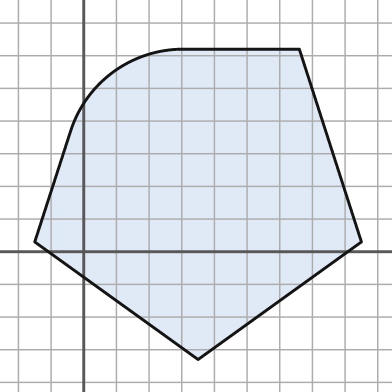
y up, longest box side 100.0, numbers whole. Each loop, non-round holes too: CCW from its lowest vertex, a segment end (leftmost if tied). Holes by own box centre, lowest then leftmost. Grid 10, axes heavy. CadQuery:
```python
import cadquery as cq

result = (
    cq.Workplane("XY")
    .moveTo(35.0, -33.0)
    .lineTo(85.0, 3.0)
    .lineTo(66.0, 62.0)
    .lineTo(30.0, 62.0)
    .threePointArc((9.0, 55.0), (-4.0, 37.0))
    .lineTo(-15.0, 3.0)
    .close()
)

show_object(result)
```